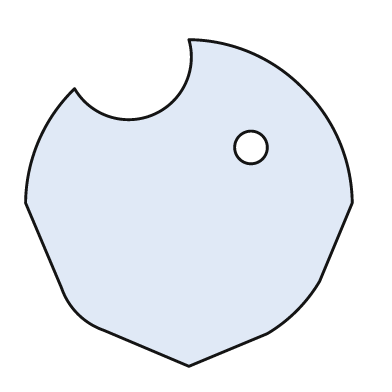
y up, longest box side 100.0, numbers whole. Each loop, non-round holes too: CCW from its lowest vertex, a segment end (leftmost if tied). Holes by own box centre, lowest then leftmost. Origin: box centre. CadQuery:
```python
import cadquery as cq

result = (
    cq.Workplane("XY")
    .moveTo(0.0, -50.0)
    .lineTo(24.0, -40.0)
    .threePointArc((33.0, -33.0), (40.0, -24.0))
    .lineTo(50.0, 0.0)
    .threePointArc((46.0, 19.0), (35.0, 35.0))
    .threePointArc((19.0, 46.0), (0.0, 50.0))
    .threePointArc((-11.0, 27.0), (-35.0, 35.0))
    .threePointArc((-46.0, 19.0), (-50.0, 0.0))
    .lineTo(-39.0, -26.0)
    .threePointArc((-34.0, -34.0), (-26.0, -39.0))
    .close()
    .moveTo(19.0, 17.0)
    .circle(5.0)
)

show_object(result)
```